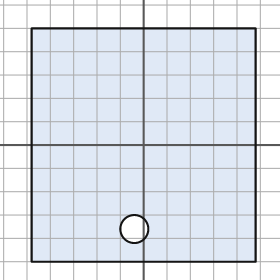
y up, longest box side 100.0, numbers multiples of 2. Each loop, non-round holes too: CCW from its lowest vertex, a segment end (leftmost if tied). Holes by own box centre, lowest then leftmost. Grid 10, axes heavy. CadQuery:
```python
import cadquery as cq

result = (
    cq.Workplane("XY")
    .moveTo(-48.0, -50.0)
    .lineTo(48.0, -50.0)
    .lineTo(48.0, 50.0)
    .lineTo(-48.0, 50.0)
    .close()
    .moveTo(-4.0, -36.0)
    .circle(6.0)
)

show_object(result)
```